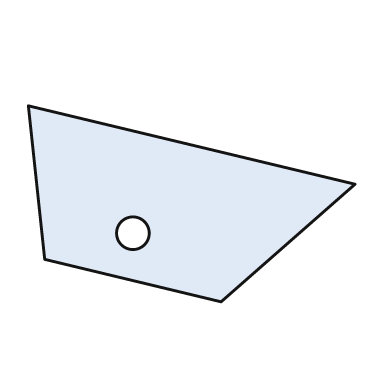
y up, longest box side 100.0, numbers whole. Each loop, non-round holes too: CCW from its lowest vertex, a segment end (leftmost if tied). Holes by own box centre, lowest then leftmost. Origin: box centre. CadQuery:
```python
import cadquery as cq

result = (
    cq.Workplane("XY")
    .moveTo(9.0, -30.0)
    .lineTo(50.0, 6.0)
    .lineTo(-50.0, 30.0)
    .lineTo(-45.0, -17.0)
    .close()
    .moveTo(-18.0, -9.0)
    .circle(5.0)
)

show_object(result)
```